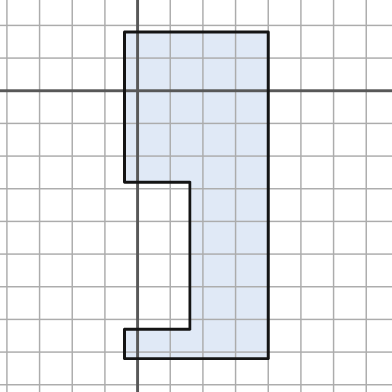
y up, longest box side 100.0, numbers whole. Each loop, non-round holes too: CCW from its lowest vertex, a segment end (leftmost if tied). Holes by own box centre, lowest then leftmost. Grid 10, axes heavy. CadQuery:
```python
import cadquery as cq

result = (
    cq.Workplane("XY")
    .moveTo(-4.0, -82.0)
    .lineTo(40.0, -82.0)
    .lineTo(40.0, 18.0)
    .lineTo(-4.0, 18.0)
    .lineTo(-4.0, -28.0)
    .lineTo(16.0, -28.0)
    .lineTo(16.0, -73.0)
    .lineTo(-4.0, -73.0)
    .close()
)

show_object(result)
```